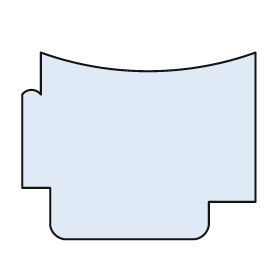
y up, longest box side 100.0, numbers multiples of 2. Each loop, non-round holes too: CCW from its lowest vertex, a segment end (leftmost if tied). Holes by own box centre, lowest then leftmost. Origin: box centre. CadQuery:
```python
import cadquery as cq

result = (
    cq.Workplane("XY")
    .moveTo(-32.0, -40.0)
    .lineTo(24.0, -40.0)
    .threePointArc((28.0, -38.0), (30.0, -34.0))
    .lineTo(30.0, -24.0)
    .lineTo(50.0, -24.0)
    .lineTo(50.0, 40.0)
    .threePointArc((4.0, 32.0), (-42.0, 40.0))
    .lineTo(-42.0, 22.0)
    .threePointArc((-46.0, 24.0), (-50.0, 22.0))
    .lineTo(-50.0, -18.0)
    .lineTo(-38.0, -18.0)
    .lineTo(-38.0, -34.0)
    .threePointArc((-36.0, -38.0), (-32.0, -40.0))
    .close()
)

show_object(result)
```